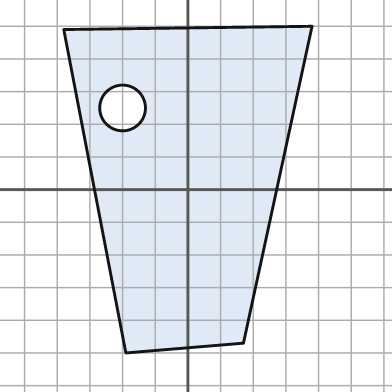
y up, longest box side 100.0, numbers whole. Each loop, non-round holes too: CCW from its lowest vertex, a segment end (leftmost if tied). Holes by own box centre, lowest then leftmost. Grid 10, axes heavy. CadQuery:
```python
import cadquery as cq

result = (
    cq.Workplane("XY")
    .moveTo(-19.0, -50.0)
    .lineTo(17.0, -47.0)
    .lineTo(38.0, 50.0)
    .lineTo(-38.0, 49.0)
    .close()
    .moveTo(-20.0, 25.0)
    .circle(7.0)
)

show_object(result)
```